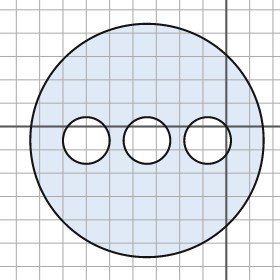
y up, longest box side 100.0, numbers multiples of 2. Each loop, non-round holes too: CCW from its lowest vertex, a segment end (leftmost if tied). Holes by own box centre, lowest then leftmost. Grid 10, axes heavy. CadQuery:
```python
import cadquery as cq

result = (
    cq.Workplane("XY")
    .moveTo(-34.0, -6.0)
    .circle(50.0)
    .moveTo(-60.0, -6.0)
    .circle(10.0)
    .moveTo(-34.0, -6.0)
    .circle(10.0)
    .moveTo(-8.0, -6.0)
    .circle(10.0)
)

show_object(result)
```